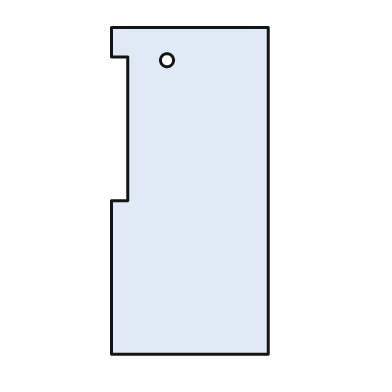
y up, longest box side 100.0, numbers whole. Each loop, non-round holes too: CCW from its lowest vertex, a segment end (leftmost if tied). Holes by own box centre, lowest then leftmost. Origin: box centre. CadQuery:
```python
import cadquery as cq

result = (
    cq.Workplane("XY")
    .moveTo(-24.0, -50.0)
    .lineTo(24.0, -50.0)
    .lineTo(24.0, 50.0)
    .lineTo(-24.0, 50.0)
    .lineTo(-24.0, 41.0)
    .lineTo(-19.0, 41.0)
    .lineTo(-19.0, -3.0)
    .lineTo(-24.0, -3.0)
    .close()
    .moveTo(-7.0, 40.0)
    .circle(2.0)
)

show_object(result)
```